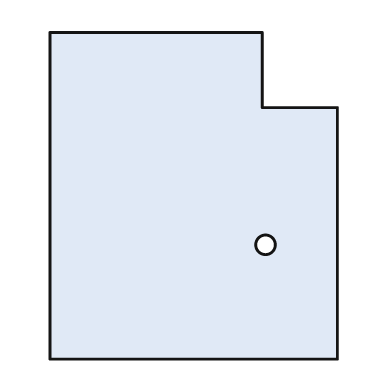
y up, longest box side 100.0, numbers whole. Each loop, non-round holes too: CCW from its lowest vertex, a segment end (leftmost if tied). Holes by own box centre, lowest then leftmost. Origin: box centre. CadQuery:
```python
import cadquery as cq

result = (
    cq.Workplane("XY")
    .moveTo(-44.0, -50.0)
    .lineTo(44.0, -50.0)
    .lineTo(44.0, 27.0)
    .lineTo(21.0, 27.0)
    .lineTo(21.0, 50.0)
    .lineTo(-44.0, 50.0)
    .close()
    .moveTo(22.0, -15.0)
    .circle(3.0)
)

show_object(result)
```